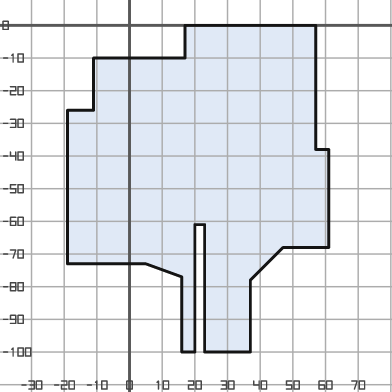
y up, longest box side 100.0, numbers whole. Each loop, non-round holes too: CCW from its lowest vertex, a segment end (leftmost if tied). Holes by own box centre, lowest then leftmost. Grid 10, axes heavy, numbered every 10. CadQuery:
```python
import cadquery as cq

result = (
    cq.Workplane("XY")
    .moveTo(16.0, -100.0)
    .lineTo(20.0, -100.0)
    .lineTo(20.0, -61.0)
    .lineTo(23.0, -61.0)
    .lineTo(23.0, -100.0)
    .lineTo(37.0, -100.0)
    .lineTo(37.0, -78.0)
    .lineTo(47.0, -68.0)
    .lineTo(61.0, -68.0)
    .lineTo(61.0, -38.0)
    .lineTo(57.0, -38.0)
    .lineTo(57.0, 0.0)
    .lineTo(17.0, 0.0)
    .lineTo(17.0, -10.0)
    .lineTo(-11.0, -10.0)
    .lineTo(-11.0, -26.0)
    .lineTo(-19.0, -26.0)
    .lineTo(-19.0, -73.0)
    .lineTo(5.0, -73.0)
    .lineTo(16.0, -77.0)
    .close()
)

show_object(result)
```